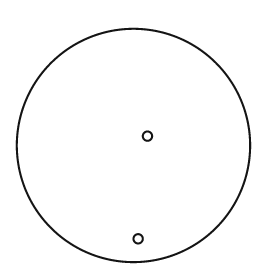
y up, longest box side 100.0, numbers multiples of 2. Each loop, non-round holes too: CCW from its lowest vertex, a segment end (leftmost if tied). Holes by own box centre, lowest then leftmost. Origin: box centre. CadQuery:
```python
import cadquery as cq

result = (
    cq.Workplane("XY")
    .moveTo(0.0, 0.0)
    .circle(50.0)
    .moveTo(2.0, -40.0)
    .circle(2.0)
    .moveTo(6.0, 4.0)
    .circle(2.0)
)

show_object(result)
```